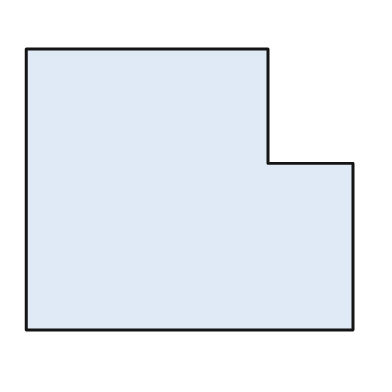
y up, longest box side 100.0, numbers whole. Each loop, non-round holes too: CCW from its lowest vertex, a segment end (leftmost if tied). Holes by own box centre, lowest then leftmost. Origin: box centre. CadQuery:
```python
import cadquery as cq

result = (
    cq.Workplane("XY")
    .moveTo(-50.0, -43.0)
    .lineTo(50.0, -43.0)
    .lineTo(50.0, 8.0)
    .lineTo(24.0, 8.0)
    .lineTo(24.0, 43.0)
    .lineTo(-50.0, 43.0)
    .close()
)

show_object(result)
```